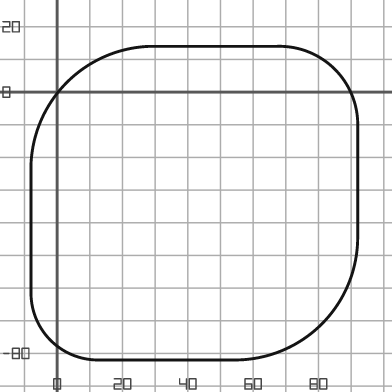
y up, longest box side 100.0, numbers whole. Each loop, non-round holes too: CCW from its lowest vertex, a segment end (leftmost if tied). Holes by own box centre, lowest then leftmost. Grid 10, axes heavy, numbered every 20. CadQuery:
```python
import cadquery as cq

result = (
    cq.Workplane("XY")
    .moveTo(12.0, -82.0)
    .lineTo(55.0, -82.0)
    .threePointArc((81.0, -71.0), (92.0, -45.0))
    .lineTo(92.0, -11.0)
    .threePointArc((85.0, 7.0), (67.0, 14.0))
    .lineTo(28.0, 14.0)
    .threePointArc((3.0, 3.0), (-8.0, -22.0))
    .lineTo(-8.0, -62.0)
    .threePointArc((-2.0, -76.0), (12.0, -82.0))
    .close()
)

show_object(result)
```